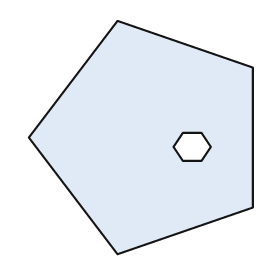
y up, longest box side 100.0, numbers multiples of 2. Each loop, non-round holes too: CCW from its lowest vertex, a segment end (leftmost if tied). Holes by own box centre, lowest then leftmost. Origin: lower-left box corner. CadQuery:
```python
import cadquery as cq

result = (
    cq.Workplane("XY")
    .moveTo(38.0, 0.0)
    .lineTo(96.0, 20.0)
    .lineTo(96.0, 80.0)
    .lineTo(38.0, 100.0)
    .lineTo(0.0, 50.0)
    .close()
    .moveTo(66.0, 40.0)
    .lineTo(74.0, 40.0)
    .lineTo(78.0, 46.0)
    .lineTo(74.0, 52.0)
    .lineTo(66.0, 52.0)
    .lineTo(62.0, 46.0)
    .close()
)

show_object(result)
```